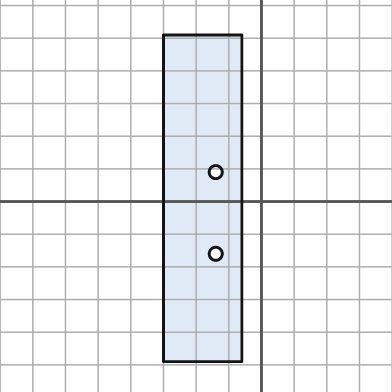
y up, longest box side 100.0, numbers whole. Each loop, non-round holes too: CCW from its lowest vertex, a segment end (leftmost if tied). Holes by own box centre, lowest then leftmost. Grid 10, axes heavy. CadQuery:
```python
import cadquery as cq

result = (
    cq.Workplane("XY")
    .moveTo(-30.0, -49.0)
    .lineTo(-6.0, -49.0)
    .lineTo(-6.0, 51.0)
    .lineTo(-30.0, 51.0)
    .close()
    .moveTo(-14.0, -16.0)
    .circle(2.0)
    .moveTo(-14.0, 9.0)
    .circle(2.0)
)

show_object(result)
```